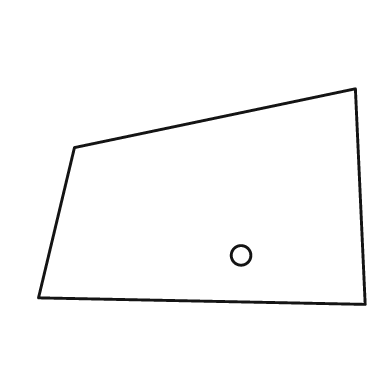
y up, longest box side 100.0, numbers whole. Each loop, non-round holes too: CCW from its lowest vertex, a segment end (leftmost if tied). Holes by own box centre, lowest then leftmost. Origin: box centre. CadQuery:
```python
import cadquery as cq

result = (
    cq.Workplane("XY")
    .moveTo(50.0, -33.0)
    .lineTo(47.0, 33.0)
    .lineTo(-39.0, 15.0)
    .lineTo(-50.0, -31.0)
    .close()
    .moveTo(12.0, -18.0)
    .circle(3.0)
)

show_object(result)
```